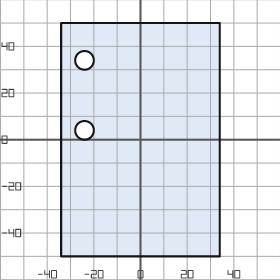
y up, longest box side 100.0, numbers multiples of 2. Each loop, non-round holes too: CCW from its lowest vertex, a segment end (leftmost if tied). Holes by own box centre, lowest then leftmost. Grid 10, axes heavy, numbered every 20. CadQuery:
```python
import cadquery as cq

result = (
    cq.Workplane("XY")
    .moveTo(-34.0, -50.0)
    .lineTo(34.0, -50.0)
    .lineTo(34.0, 50.0)
    .lineTo(-34.0, 50.0)
    .close()
    .moveTo(-24.0, 4.0)
    .circle(4.0)
    .moveTo(-24.0, 34.0)
    .circle(4.0)
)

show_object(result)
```